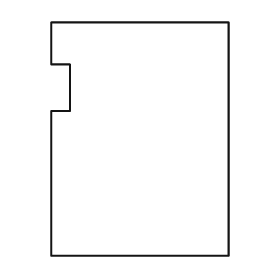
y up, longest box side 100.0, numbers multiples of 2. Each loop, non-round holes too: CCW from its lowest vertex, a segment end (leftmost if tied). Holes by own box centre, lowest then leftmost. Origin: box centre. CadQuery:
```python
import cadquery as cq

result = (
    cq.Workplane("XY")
    .moveTo(-38.0, -50.0)
    .lineTo(38.0, -50.0)
    .lineTo(38.0, 50.0)
    .lineTo(-38.0, 50.0)
    .lineTo(-38.0, 32.0)
    .lineTo(-30.0, 32.0)
    .lineTo(-30.0, 12.0)
    .lineTo(-38.0, 12.0)
    .close()
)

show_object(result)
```